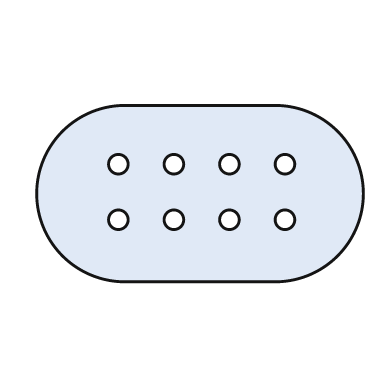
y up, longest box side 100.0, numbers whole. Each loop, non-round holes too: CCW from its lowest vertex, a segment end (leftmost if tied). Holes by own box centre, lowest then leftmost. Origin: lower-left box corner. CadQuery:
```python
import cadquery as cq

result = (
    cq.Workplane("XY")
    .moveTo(27.0, 0.0)
    .lineTo(73.0, 0.0)
    .threePointArc((100.0, 27.0), (73.0, 54.0))
    .lineTo(27.0, 54.0)
    .threePointArc((0.0, 27.0), (27.0, 0.0))
    .close()
    .moveTo(25.0, 19.0)
    .circle(3.0)
    .moveTo(42.0, 19.0)
    .circle(3.0)
    .moveTo(59.0, 19.0)
    .circle(3.0)
    .moveTo(76.0, 19.0)
    .circle(3.0)
    .moveTo(25.0, 36.0)
    .circle(3.0)
    .moveTo(42.0, 36.0)
    .circle(3.0)
    .moveTo(59.0, 36.0)
    .circle(3.0)
    .moveTo(76.0, 36.0)
    .circle(3.0)
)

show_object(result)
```